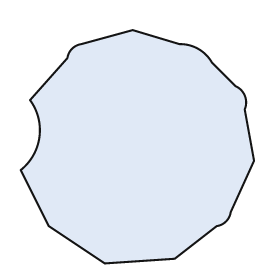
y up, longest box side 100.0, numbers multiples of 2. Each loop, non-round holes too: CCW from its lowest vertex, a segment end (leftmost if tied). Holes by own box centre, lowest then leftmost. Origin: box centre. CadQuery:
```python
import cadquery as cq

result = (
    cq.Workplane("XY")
    .moveTo(-14.0, -50.0)
    .lineTo(16.0, -48.0)
    .lineTo(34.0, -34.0)
    .threePointArc((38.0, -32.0), (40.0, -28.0))
    .lineTo(50.0, -6.0)
    .lineTo(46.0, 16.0)
    .threePointArc((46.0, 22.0), (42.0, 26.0))
    .lineTo(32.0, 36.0)
    .threePointArc((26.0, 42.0), (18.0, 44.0))
    .lineTo(-2.0, 50.0)
    .lineTo(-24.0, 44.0)
    .threePointArc((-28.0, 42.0), (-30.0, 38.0))
    .lineTo(-46.0, 20.0)
    .threePointArc((-42.0, 4.0), (-50.0, -10.0))
    .lineTo(-38.0, -34.0)
    .close()
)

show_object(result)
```